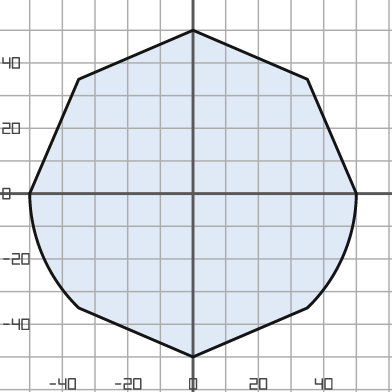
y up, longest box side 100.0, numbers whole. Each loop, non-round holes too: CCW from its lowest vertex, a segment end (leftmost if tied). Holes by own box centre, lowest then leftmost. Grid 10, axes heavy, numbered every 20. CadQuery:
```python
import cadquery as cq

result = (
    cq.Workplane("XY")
    .moveTo(0.0, -50.0)
    .lineTo(35.0, -35.0)
    .threePointArc((46.0, -19.0), (50.0, 0.0))
    .lineTo(35.0, 35.0)
    .lineTo(0.0, 50.0)
    .lineTo(-35.0, 35.0)
    .lineTo(-50.0, 0.0)
    .threePointArc((-46.0, -19.0), (-35.0, -35.0))
    .close()
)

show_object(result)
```